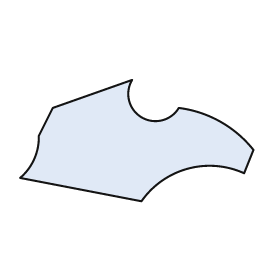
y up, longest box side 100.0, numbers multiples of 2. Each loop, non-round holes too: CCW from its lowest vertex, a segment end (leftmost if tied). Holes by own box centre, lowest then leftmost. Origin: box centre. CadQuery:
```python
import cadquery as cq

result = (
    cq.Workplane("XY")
    .moveTo(2.0, -26.0)
    .threePointArc((22.0, -12.0), (46.0, -14.0))
    .lineTo(50.0, -4.0)
    .threePointArc((36.0, 8.0), (18.0, 14.0))
    .threePointArc((2.0, 10.0), (-2.0, 26.0))
    .lineTo(-36.0, 14.0)
    .lineTo(-42.0, 2.0)
    .threePointArc((-44.0, -8.0), (-50.0, -16.0))
    .close()
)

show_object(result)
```